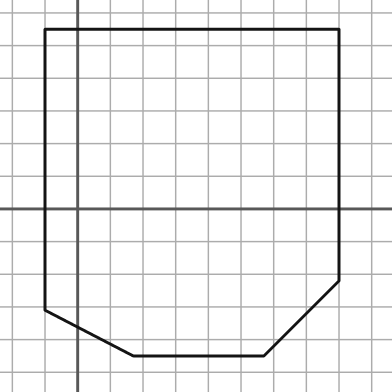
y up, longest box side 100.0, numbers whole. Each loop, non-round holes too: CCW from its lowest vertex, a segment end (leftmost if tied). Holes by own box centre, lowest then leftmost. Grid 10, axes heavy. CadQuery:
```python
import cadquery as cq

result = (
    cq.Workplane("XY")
    .moveTo(17.0, -45.0)
    .lineTo(57.0, -45.0)
    .lineTo(80.0, -22.0)
    .lineTo(80.0, 55.0)
    .lineTo(-10.0, 55.0)
    .lineTo(-10.0, -31.0)
    .close()
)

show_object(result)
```